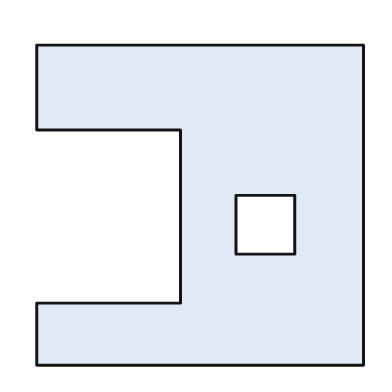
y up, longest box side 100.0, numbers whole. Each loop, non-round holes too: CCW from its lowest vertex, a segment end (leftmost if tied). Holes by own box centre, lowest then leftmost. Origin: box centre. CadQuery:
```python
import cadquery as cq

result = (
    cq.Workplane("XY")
    .moveTo(-50.0, -49.0)
    .lineTo(50.0, -49.0)
    .lineTo(50.0, 49.0)
    .lineTo(-50.0, 49.0)
    .lineTo(-50.0, 23.0)
    .lineTo(-6.0, 23.0)
    .lineTo(-6.0, -30.0)
    .lineTo(-50.0, -30.0)
    .close()
    .moveTo(11.0, -15.0)
    .lineTo(29.0, -15.0)
    .lineTo(29.0, 3.0)
    .lineTo(11.0, 3.0)
    .close()
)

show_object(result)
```